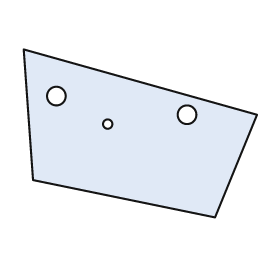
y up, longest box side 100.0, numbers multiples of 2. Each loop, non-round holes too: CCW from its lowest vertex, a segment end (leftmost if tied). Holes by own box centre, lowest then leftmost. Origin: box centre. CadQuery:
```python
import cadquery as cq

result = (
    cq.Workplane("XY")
    .moveTo(32.0, -36.0)
    .lineTo(50.0, 8.0)
    .lineTo(-50.0, 36.0)
    .lineTo(-46.0, -20.0)
    .close()
    .moveTo(-14.0, 4.0)
    .circle(2.0)
    .moveTo(20.0, 8.0)
    .circle(4.0)
    .moveTo(-36.0, 16.0)
    .circle(4.0)
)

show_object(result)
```